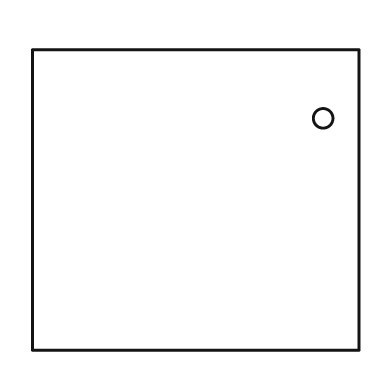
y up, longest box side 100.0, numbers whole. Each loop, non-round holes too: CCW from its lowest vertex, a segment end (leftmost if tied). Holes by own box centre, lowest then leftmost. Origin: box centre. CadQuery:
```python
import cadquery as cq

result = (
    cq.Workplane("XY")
    .moveTo(-50.0, -46.0)
    .lineTo(50.0, -46.0)
    .lineTo(50.0, 46.0)
    .lineTo(-50.0, 46.0)
    .close()
    .moveTo(39.0, 25.0)
    .circle(3.0)
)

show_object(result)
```